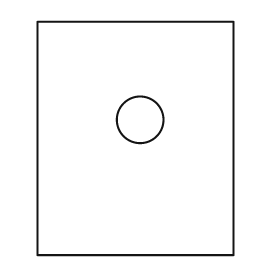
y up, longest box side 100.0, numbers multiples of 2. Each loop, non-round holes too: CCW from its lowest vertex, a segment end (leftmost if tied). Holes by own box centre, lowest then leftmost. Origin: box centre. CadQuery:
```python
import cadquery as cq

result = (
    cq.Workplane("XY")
    .moveTo(-42.0, -50.0)
    .lineTo(42.0, -50.0)
    .lineTo(42.0, 50.0)
    .lineTo(-42.0, 50.0)
    .close()
    .moveTo(2.0, 8.0)
    .circle(10.0)
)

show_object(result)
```